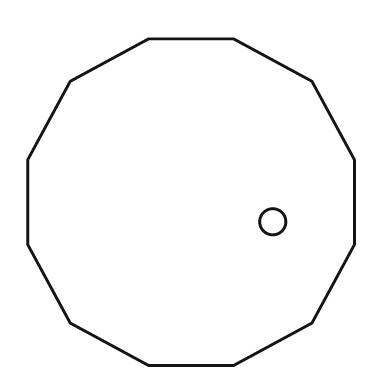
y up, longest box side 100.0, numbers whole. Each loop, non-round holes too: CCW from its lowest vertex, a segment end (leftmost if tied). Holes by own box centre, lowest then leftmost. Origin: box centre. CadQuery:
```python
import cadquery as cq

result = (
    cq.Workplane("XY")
    .moveTo(-13.0, -50.0)
    .lineTo(13.0, -50.0)
    .lineTo(37.0, -37.0)
    .lineTo(50.0, -13.0)
    .lineTo(50.0, 13.0)
    .lineTo(37.0, 37.0)
    .lineTo(13.0, 50.0)
    .lineTo(-13.0, 50.0)
    .lineTo(-37.0, 37.0)
    .lineTo(-50.0, 13.0)
    .lineTo(-50.0, -13.0)
    .lineTo(-37.0, -37.0)
    .close()
    .moveTo(25.0, -6.0)
    .circle(4.0)
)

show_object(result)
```